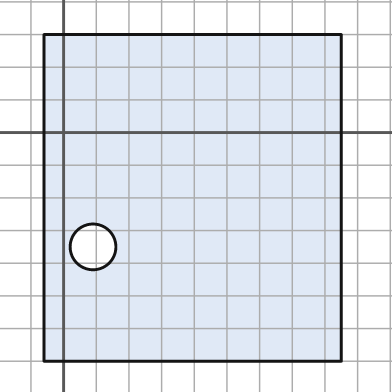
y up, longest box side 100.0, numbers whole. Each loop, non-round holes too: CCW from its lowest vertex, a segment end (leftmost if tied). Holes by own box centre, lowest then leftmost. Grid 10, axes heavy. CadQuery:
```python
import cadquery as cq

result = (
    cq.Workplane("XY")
    .moveTo(-6.0, -70.0)
    .lineTo(85.0, -70.0)
    .lineTo(85.0, 30.0)
    .lineTo(-6.0, 30.0)
    .close()
    .moveTo(9.0, -35.0)
    .circle(7.0)
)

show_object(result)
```